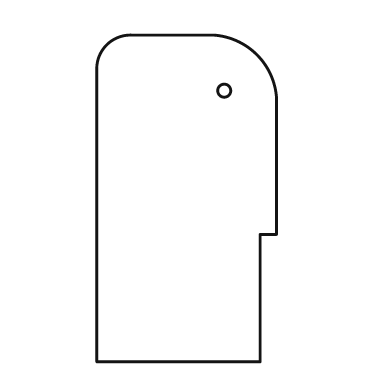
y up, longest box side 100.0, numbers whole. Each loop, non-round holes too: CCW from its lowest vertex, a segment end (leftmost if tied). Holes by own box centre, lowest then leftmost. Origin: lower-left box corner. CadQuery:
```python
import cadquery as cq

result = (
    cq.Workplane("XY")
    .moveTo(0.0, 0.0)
    .lineTo(50.0, 0.0)
    .lineTo(50.0, 39.0)
    .lineTo(55.0, 39.0)
    .lineTo(55.0, 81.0)
    .threePointArc((49.0, 94.0), (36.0, 100.0))
    .lineTo(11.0, 100.0)
    .threePointArc((3.0, 97.0), (0.0, 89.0))
    .close()
    .moveTo(39.0, 83.0)
    .circle(2.0)
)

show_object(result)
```